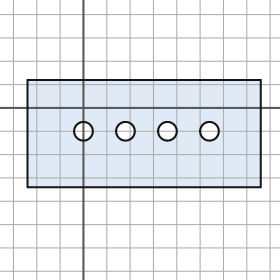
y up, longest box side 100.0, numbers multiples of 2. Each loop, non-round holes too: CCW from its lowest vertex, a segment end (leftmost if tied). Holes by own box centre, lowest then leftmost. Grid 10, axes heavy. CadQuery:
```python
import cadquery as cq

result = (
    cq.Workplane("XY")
    .moveTo(-24.0, -34.0)
    .lineTo(76.0, -34.0)
    .lineTo(76.0, 12.0)
    .lineTo(-24.0, 12.0)
    .close()
    .moveTo(0.0, -10.0)
    .circle(4.0)
    .moveTo(18.0, -10.0)
    .circle(4.0)
    .moveTo(36.0, -10.0)
    .circle(4.0)
    .moveTo(54.0, -10.0)
    .circle(4.0)
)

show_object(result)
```